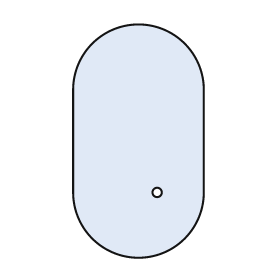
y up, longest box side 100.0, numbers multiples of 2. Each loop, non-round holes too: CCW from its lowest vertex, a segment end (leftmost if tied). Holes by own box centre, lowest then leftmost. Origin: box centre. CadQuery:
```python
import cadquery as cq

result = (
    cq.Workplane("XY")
    .moveTo(-28.0, -22.0)
    .threePointArc((0.0, -50.0), (28.0, -22.0))
    .lineTo(28.0, 22.0)
    .threePointArc((0.0, 50.0), (-28.0, 22.0))
    .close()
    .moveTo(8.0, -22.0)
    .circle(2.0)
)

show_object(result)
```